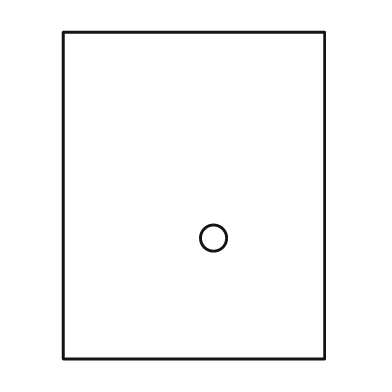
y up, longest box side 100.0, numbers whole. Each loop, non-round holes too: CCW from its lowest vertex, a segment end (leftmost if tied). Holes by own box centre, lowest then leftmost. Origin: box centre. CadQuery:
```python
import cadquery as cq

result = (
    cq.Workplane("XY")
    .moveTo(-40.0, -50.0)
    .lineTo(40.0, -50.0)
    .lineTo(40.0, 50.0)
    .lineTo(-40.0, 50.0)
    .close()
    .moveTo(6.0, -13.0)
    .circle(4.0)
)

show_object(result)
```